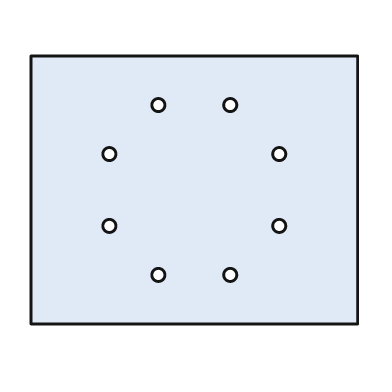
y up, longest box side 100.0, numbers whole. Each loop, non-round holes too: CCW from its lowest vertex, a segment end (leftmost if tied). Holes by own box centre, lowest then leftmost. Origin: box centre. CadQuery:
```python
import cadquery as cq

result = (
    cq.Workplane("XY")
    .moveTo(-50.0, -41.0)
    .lineTo(50.0, -41.0)
    .lineTo(50.0, 41.0)
    .lineTo(-50.0, 41.0)
    .close()
    .moveTo(-11.0, -26.0)
    .circle(2.0)
    .moveTo(11.0, -26.0)
    .circle(2.0)
    .moveTo(-26.0, -11.0)
    .circle(2.0)
    .moveTo(26.0, -11.0)
    .circle(2.0)
    .moveTo(-26.0, 11.0)
    .circle(2.0)
    .moveTo(26.0, 11.0)
    .circle(2.0)
    .moveTo(-11.0, 26.0)
    .circle(2.0)
    .moveTo(11.0, 26.0)
    .circle(2.0)
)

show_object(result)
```